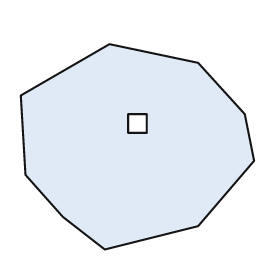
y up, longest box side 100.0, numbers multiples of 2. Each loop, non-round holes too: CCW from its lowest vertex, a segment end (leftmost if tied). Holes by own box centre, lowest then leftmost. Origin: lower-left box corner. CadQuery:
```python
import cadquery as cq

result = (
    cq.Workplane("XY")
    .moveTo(36.0, 0.0)
    .lineTo(76.0, 10.0)
    .lineTo(100.0, 38.0)
    .lineTo(96.0, 58.0)
    .lineTo(76.0, 80.0)
    .lineTo(38.0, 88.0)
    .lineTo(0.0, 66.0)
    .lineTo(2.0, 32.0)
    .lineTo(18.0, 14.0)
    .close()
    .moveTo(46.0, 50.0)
    .lineTo(54.0, 50.0)
    .lineTo(54.0, 58.0)
    .lineTo(46.0, 58.0)
    .close()
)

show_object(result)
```